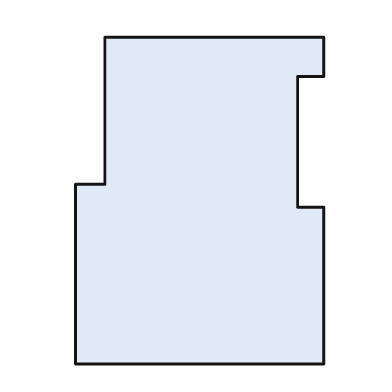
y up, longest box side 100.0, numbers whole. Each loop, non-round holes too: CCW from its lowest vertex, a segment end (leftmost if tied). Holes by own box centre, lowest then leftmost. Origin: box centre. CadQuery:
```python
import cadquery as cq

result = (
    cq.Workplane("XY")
    .moveTo(-38.0, -50.0)
    .lineTo(38.0, -50.0)
    .lineTo(38.0, -2.0)
    .lineTo(30.0, -2.0)
    .lineTo(30.0, 38.0)
    .lineTo(38.0, 38.0)
    .lineTo(38.0, 50.0)
    .lineTo(-29.0, 50.0)
    .lineTo(-29.0, 5.0)
    .lineTo(-38.0, 5.0)
    .close()
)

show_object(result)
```